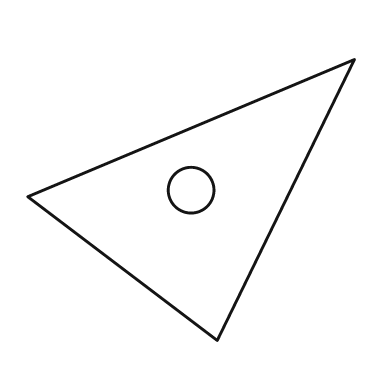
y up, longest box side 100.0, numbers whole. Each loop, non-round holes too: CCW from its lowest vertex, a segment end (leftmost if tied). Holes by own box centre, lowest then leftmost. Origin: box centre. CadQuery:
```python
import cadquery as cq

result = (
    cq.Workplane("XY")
    .moveTo(8.0, -43.0)
    .lineTo(50.0, 43.0)
    .lineTo(-50.0, 1.0)
    .close()
    .moveTo(0.0, 3.0)
    .circle(7.0)
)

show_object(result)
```